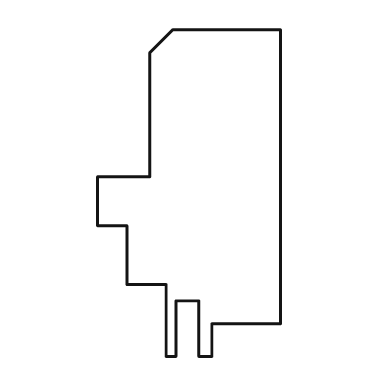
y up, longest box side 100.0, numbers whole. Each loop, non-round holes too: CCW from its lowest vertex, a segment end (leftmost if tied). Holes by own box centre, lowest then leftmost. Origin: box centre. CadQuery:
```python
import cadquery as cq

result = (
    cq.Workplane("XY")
    .moveTo(-7.0, -50.0)
    .lineTo(-4.0, -50.0)
    .lineTo(-4.0, -33.0)
    .lineTo(3.0, -33.0)
    .lineTo(3.0, -50.0)
    .lineTo(7.0, -50.0)
    .lineTo(7.0, -40.0)
    .lineTo(28.0, -40.0)
    .lineTo(28.0, 50.0)
    .lineTo(-5.0, 50.0)
    .lineTo(-12.0, 43.0)
    .lineTo(-12.0, 5.0)
    .lineTo(-28.0, 5.0)
    .lineTo(-28.0, -10.0)
    .lineTo(-19.0, -10.0)
    .lineTo(-19.0, -28.0)
    .lineTo(-7.0, -28.0)
    .close()
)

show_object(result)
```